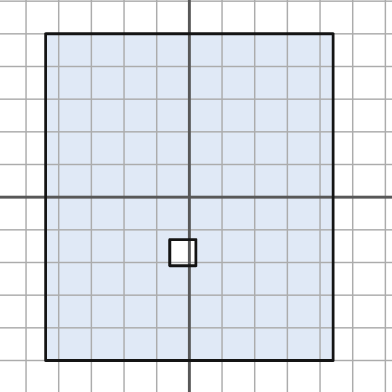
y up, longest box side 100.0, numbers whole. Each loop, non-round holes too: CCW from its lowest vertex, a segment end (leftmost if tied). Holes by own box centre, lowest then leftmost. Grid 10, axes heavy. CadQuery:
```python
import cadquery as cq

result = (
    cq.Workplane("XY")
    .moveTo(-44.0, -50.0)
    .lineTo(44.0, -50.0)
    .lineTo(44.0, 50.0)
    .lineTo(-44.0, 50.0)
    .close()
    .moveTo(-6.0, -21.0)
    .lineTo(2.0, -21.0)
    .lineTo(2.0, -13.0)
    .lineTo(-6.0, -13.0)
    .close()
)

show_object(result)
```